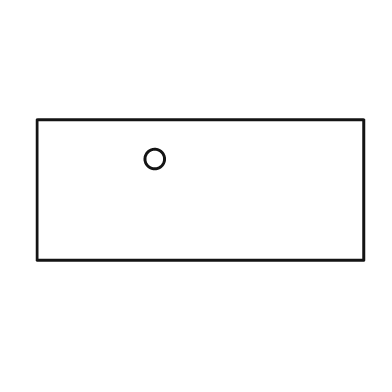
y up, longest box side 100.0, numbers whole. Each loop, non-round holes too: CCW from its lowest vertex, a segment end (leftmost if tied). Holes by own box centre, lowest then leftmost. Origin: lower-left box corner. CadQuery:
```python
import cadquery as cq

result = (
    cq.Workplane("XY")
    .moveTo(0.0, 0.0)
    .lineTo(100.0, 0.0)
    .lineTo(100.0, 43.0)
    .lineTo(0.0, 43.0)
    .close()
    .moveTo(36.0, 31.0)
    .circle(3.0)
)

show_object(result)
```